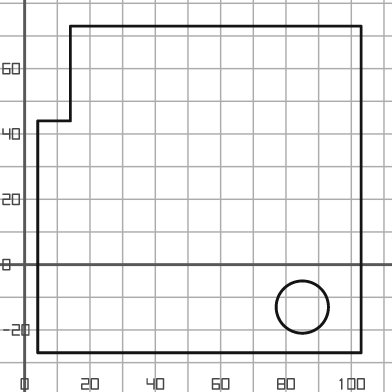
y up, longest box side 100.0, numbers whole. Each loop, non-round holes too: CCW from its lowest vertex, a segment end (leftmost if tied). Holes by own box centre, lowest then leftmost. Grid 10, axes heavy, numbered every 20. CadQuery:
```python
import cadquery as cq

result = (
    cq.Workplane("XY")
    .moveTo(4.0, -27.0)
    .lineTo(103.0, -27.0)
    .lineTo(103.0, 73.0)
    .lineTo(14.0, 73.0)
    .lineTo(14.0, 44.0)
    .lineTo(4.0, 44.0)
    .close()
    .moveTo(85.0, -13.0)
    .circle(8.0)
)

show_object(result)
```